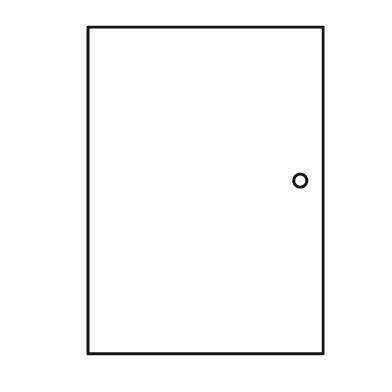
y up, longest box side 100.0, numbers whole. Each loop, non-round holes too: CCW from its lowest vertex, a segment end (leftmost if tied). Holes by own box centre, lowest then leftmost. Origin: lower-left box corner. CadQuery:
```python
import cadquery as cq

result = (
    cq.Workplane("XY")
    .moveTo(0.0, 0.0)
    .lineTo(72.0, 0.0)
    .lineTo(72.0, 100.0)
    .lineTo(0.0, 100.0)
    .close()
    .moveTo(65.0, 53.0)
    .circle(2.0)
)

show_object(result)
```